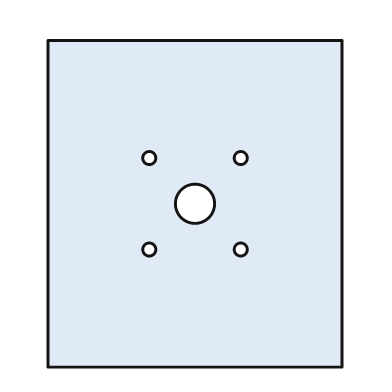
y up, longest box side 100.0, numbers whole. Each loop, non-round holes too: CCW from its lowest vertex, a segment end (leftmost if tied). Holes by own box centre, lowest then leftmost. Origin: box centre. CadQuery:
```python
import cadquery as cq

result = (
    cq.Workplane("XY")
    .moveTo(-45.0, -50.0)
    .lineTo(45.0, -50.0)
    .lineTo(45.0, 50.0)
    .lineTo(-45.0, 50.0)
    .close()
    .moveTo(-14.0, -14.0)
    .circle(2.0)
    .moveTo(14.0, -14.0)
    .circle(2.0)
    .moveTo(0.0, 0.0)
    .circle(6.0)
    .moveTo(-14.0, 14.0)
    .circle(2.0)
    .moveTo(14.0, 14.0)
    .circle(2.0)
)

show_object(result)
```